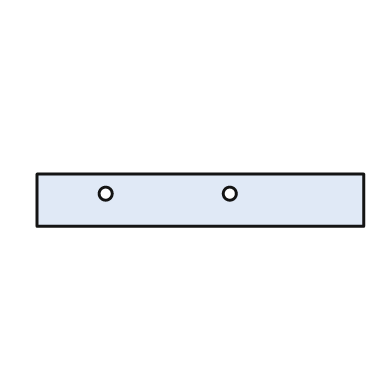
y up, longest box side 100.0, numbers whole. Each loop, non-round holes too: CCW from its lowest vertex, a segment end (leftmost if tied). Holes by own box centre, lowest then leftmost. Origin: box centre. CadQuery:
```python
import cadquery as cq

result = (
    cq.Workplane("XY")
    .moveTo(-50.0, -8.0)
    .lineTo(50.0, -8.0)
    .lineTo(50.0, 8.0)
    .lineTo(-50.0, 8.0)
    .close()
    .moveTo(-29.0, 2.0)
    .circle(2.0)
    .moveTo(9.0, 2.0)
    .circle(2.0)
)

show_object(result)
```